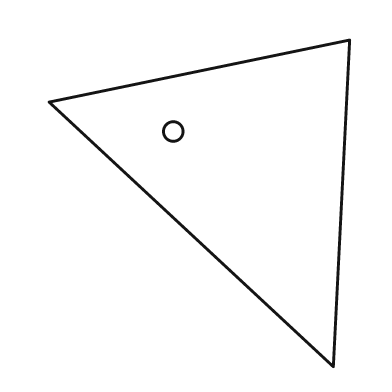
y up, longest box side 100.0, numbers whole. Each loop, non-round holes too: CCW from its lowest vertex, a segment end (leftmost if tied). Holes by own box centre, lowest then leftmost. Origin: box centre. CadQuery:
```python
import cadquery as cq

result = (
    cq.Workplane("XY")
    .moveTo(41.0, -50.0)
    .lineTo(46.0, 50.0)
    .lineTo(-46.0, 31.0)
    .close()
    .moveTo(-8.0, 22.0)
    .circle(3.0)
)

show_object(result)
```